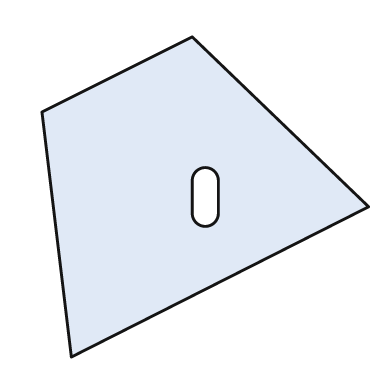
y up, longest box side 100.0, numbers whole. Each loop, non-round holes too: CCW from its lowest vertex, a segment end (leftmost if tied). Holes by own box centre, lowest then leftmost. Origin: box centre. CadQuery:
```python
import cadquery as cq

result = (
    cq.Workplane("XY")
    .moveTo(-41.0, -49.0)
    .lineTo(50.0, -3.0)
    .lineTo(-4.0, 49.0)
    .lineTo(-50.0, 26.0)
    .close()
    .moveTo(-4.0, -5.0)
    .threePointArc((0.0, -9.0), (4.0, -5.0))
    .lineTo(4.0, 5.0)
    .threePointArc((0.0, 9.0), (-4.0, 5.0))
    .close()
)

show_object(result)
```